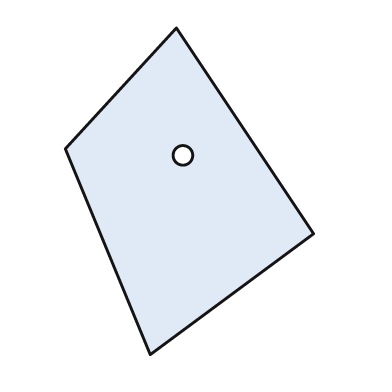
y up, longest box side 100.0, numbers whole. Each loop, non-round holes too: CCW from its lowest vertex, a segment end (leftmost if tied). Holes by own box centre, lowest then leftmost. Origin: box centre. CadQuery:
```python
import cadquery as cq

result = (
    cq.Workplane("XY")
    .moveTo(-12.0, -50.0)
    .lineTo(38.0, -13.0)
    .lineTo(-4.0, 50.0)
    .lineTo(-38.0, 13.0)
    .close()
    .moveTo(-2.0, 11.0)
    .circle(3.0)
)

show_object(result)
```